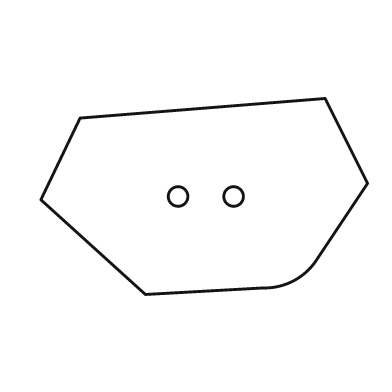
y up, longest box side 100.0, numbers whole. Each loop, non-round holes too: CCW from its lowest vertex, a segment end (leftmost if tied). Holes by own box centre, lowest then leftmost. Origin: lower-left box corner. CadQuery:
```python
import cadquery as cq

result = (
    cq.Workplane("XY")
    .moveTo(32.0, 0.0)
    .lineTo(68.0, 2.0)
    .threePointArc((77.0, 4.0), (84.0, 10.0))
    .lineTo(100.0, 34.0)
    .lineTo(87.0, 60.0)
    .lineTo(12.0, 54.0)
    .lineTo(0.0, 29.0)
    .close()
    .moveTo(42.0, 30.0)
    .circle(3.0)
    .moveTo(59.0, 30.0)
    .circle(3.0)
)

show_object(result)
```